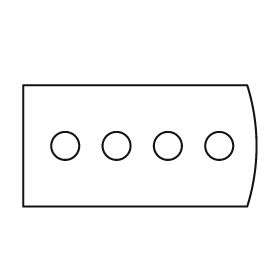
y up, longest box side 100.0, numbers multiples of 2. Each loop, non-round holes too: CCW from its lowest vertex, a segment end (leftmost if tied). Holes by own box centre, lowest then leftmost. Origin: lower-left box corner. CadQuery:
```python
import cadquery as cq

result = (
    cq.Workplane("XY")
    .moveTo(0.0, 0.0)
    .lineTo(96.0, 0.0)
    .threePointArc((100.0, 26.0), (96.0, 52.0))
    .lineTo(0.0, 52.0)
    .close()
    .moveTo(18.0, 26.0)
    .circle(6.0)
    .moveTo(40.0, 26.0)
    .circle(6.0)
    .moveTo(62.0, 26.0)
    .circle(6.0)
    .moveTo(84.0, 26.0)
    .circle(6.0)
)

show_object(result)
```